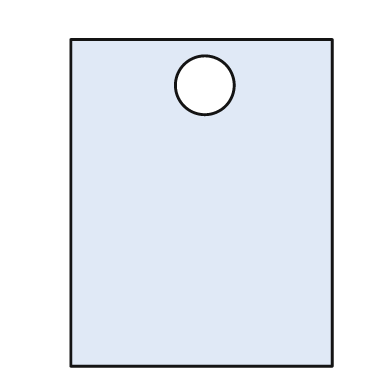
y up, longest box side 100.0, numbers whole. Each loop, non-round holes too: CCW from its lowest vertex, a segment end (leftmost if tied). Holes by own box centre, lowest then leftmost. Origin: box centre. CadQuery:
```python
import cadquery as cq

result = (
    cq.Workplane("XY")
    .moveTo(-40.0, -50.0)
    .lineTo(40.0, -50.0)
    .lineTo(40.0, 50.0)
    .lineTo(-40.0, 50.0)
    .close()
    .moveTo(1.0, 36.0)
    .circle(9.0)
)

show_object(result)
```